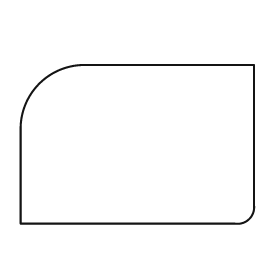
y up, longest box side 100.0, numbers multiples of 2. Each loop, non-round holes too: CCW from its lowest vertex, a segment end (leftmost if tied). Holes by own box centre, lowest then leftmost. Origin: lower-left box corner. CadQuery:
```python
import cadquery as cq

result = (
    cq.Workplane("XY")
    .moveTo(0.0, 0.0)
    .lineTo(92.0, 0.0)
    .threePointArc((98.0, 2.0), (100.0, 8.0))
    .lineTo(100.0, 68.0)
    .lineTo(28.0, 68.0)
    .threePointArc((8.0, 60.0), (0.0, 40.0))
    .close()
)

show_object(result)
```